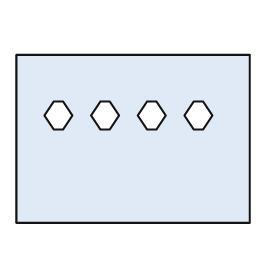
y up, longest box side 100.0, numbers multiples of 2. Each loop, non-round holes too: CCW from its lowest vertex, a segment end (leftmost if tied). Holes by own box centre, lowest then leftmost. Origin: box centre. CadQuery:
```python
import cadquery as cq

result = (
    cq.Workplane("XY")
    .moveTo(-50.0, -36.0)
    .lineTo(50.0, -36.0)
    .lineTo(50.0, 36.0)
    .lineTo(-50.0, 36.0)
    .close()
    .moveTo(-34.0, 4.0)
    .lineTo(-30.0, 4.0)
    .lineTo(-26.0, 10.0)
    .lineTo(-30.0, 16.0)
    .lineTo(-34.0, 16.0)
    .lineTo(-38.0, 10.0)
    .close()
    .moveTo(-14.0, 4.0)
    .lineTo(-10.0, 4.0)
    .lineTo(-6.0, 10.0)
    .lineTo(-10.0, 16.0)
    .lineTo(-14.0, 16.0)
    .lineTo(-18.0, 10.0)
    .close()
    .moveTo(6.0, 4.0)
    .lineTo(10.0, 4.0)
    .lineTo(14.0, 10.0)
    .lineTo(10.0, 16.0)
    .lineTo(6.0, 16.0)
    .lineTo(2.0, 10.0)
    .close()
    .moveTo(26.0, 4.0)
    .lineTo(30.0, 4.0)
    .lineTo(34.0, 10.0)
    .lineTo(30.0, 16.0)
    .lineTo(26.0, 16.0)
    .lineTo(22.0, 10.0)
    .close()
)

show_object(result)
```